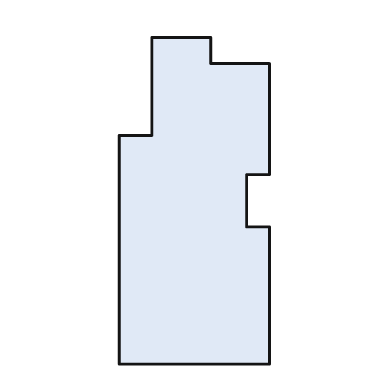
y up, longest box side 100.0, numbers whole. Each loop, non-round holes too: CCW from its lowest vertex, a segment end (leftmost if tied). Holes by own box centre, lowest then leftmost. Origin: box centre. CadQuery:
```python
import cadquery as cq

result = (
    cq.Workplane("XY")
    .moveTo(-23.0, -50.0)
    .lineTo(23.0, -50.0)
    .lineTo(23.0, -8.0)
    .lineTo(16.0, -8.0)
    .lineTo(16.0, 8.0)
    .lineTo(23.0, 8.0)
    .lineTo(23.0, 42.0)
    .lineTo(5.0, 42.0)
    .lineTo(5.0, 50.0)
    .lineTo(-13.0, 50.0)
    .lineTo(-13.0, 20.0)
    .lineTo(-23.0, 20.0)
    .close()
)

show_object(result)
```